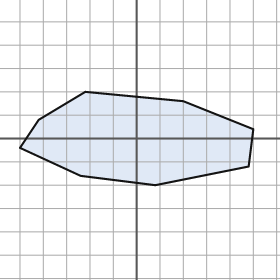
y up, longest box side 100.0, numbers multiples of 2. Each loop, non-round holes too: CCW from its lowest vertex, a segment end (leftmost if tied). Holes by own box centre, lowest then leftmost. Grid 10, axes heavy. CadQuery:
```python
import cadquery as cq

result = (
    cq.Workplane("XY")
    .moveTo(8.0, -20.0)
    .lineTo(48.0, -12.0)
    .lineTo(50.0, 4.0)
    .lineTo(20.0, 16.0)
    .lineTo(-22.0, 20.0)
    .lineTo(-42.0, 8.0)
    .lineTo(-50.0, -4.0)
    .lineTo(-24.0, -16.0)
    .close()
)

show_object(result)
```